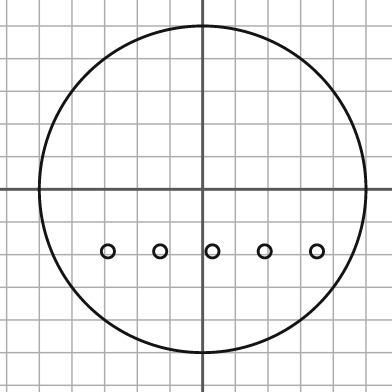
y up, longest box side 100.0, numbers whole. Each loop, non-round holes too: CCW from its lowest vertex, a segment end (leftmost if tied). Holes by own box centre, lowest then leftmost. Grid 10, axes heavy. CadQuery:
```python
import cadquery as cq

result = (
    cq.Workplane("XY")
    .moveTo(0.0, 0.0)
    .circle(50.0)
    .moveTo(-29.0, -19.0)
    .circle(2.0)
    .moveTo(-13.0, -19.0)
    .circle(2.0)
    .moveTo(3.0, -19.0)
    .circle(2.0)
    .moveTo(19.0, -19.0)
    .circle(2.0)
    .moveTo(35.0, -19.0)
    .circle(2.0)
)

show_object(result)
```